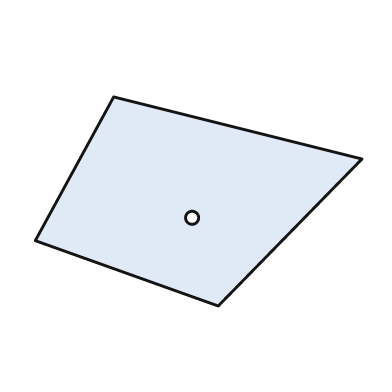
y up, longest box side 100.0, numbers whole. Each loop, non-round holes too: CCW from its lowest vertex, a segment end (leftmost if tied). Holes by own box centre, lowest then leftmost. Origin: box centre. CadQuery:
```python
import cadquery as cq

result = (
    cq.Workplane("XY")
    .moveTo(6.0, -32.0)
    .lineTo(50.0, 13.0)
    .lineTo(-26.0, 32.0)
    .lineTo(-50.0, -12.0)
    .close()
    .moveTo(-2.0, -5.0)
    .circle(2.0)
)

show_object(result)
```